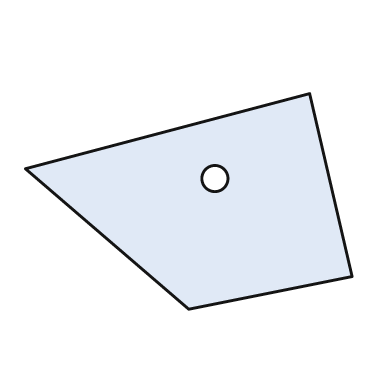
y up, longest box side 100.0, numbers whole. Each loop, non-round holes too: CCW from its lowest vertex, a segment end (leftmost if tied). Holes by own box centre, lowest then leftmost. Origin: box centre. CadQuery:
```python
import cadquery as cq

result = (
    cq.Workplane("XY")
    .moveTo(0.0, -33.0)
    .lineTo(50.0, -23.0)
    .lineTo(37.0, 33.0)
    .lineTo(-50.0, 10.0)
    .close()
    .moveTo(8.0, 7.0)
    .circle(4.0)
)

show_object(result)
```